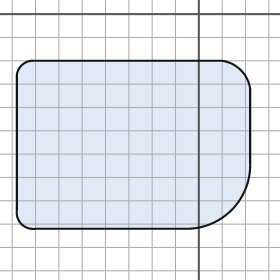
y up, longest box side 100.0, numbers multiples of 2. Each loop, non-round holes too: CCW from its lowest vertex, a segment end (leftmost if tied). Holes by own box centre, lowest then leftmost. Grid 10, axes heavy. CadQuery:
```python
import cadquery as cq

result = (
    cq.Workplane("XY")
    .moveTo(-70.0, -92.0)
    .lineTo(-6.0, -92.0)
    .threePointArc((14.0, -84.0), (22.0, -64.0))
    .lineTo(22.0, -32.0)
    .threePointArc((18.0, -24.0), (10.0, -20.0))
    .lineTo(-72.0, -20.0)
    .threePointArc((-76.0, -22.0), (-78.0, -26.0))
    .lineTo(-78.0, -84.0)
    .threePointArc((-76.0, -90.0), (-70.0, -92.0))
    .close()
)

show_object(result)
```